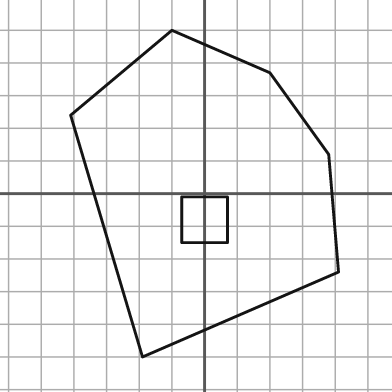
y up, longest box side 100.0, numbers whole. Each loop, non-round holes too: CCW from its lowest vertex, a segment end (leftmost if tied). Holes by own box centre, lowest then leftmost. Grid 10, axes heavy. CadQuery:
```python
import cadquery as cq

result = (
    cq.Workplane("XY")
    .moveTo(-19.0, -50.0)
    .lineTo(41.0, -24.0)
    .lineTo(38.0, 12.0)
    .lineTo(20.0, 37.0)
    .lineTo(-10.0, 50.0)
    .lineTo(-41.0, 24.0)
    .close()
    .moveTo(-7.0, -15.0)
    .lineTo(7.0, -15.0)
    .lineTo(7.0, -1.0)
    .lineTo(-7.0, -1.0)
    .close()
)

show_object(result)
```